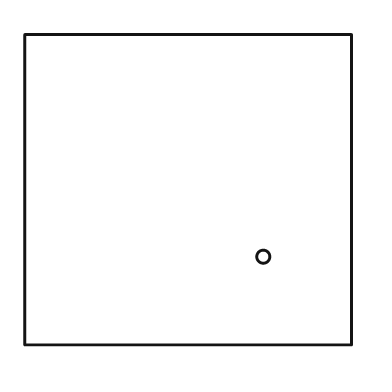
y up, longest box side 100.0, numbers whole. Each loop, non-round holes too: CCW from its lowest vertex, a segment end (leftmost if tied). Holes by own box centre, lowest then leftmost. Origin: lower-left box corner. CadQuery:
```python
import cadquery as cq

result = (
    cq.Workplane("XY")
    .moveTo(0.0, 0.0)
    .lineTo(100.0, 0.0)
    .lineTo(100.0, 95.0)
    .lineTo(0.0, 95.0)
    .close()
    .moveTo(73.0, 27.0)
    .circle(2.0)
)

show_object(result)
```